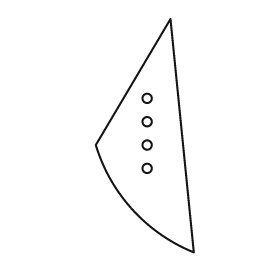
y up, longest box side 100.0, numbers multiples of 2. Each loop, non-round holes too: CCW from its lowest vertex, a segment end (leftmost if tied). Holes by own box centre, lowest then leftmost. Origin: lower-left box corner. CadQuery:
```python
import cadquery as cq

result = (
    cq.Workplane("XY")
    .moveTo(42.0, 0.0)
    .lineTo(32.0, 100.0)
    .lineTo(0.0, 46.0)
    .threePointArc((16.0, 18.0), (42.0, 0.0))
    .close()
    .moveTo(22.0, 36.0)
    .circle(2.0)
    .moveTo(22.0, 46.0)
    .circle(2.0)
    .moveTo(22.0, 56.0)
    .circle(2.0)
    .moveTo(22.0, 66.0)
    .circle(2.0)
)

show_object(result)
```